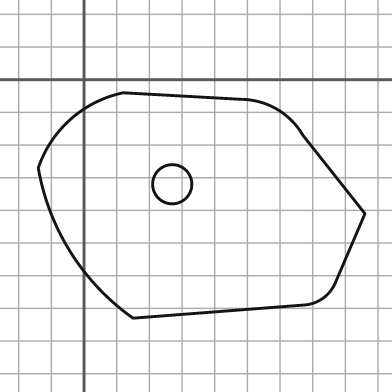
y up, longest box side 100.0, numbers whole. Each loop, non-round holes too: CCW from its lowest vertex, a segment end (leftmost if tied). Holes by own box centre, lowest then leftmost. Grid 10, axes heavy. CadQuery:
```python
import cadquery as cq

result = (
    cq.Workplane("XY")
    .moveTo(15.0, -73.0)
    .lineTo(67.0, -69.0)
    .threePointArc((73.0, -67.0), (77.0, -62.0))
    .lineTo(86.0, -41.0)
    .lineTo(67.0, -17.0)
    .threePointArc((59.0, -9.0), (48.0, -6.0))
    .lineTo(12.0, -4.0)
    .threePointArc((-4.0, -12.0), (-14.0, -27.0))
    .threePointArc((-4.0, -53.0), (15.0, -73.0))
    .close()
    .moveTo(27.0, -32.0)
    .circle(6.0)
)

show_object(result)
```